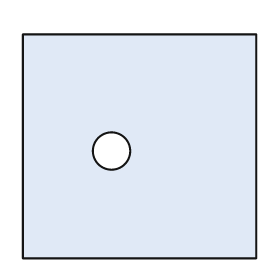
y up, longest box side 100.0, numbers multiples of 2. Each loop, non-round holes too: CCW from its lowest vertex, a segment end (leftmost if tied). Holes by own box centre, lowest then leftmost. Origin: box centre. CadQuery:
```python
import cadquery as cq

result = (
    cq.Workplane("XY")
    .moveTo(-50.0, -48.0)
    .lineTo(50.0, -48.0)
    .lineTo(50.0, 48.0)
    .lineTo(-50.0, 48.0)
    .close()
    .moveTo(-12.0, -2.0)
    .circle(8.0)
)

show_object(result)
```